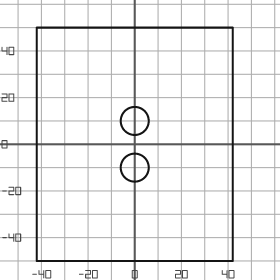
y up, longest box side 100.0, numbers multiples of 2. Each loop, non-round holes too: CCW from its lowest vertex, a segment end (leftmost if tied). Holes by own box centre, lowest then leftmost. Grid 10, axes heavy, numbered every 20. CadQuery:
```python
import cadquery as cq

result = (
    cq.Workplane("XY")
    .moveTo(-42.0, -50.0)
    .lineTo(42.0, -50.0)
    .lineTo(42.0, 50.0)
    .lineTo(-42.0, 50.0)
    .close()
    .moveTo(0.0, -10.0)
    .circle(6.0)
    .moveTo(0.0, 10.0)
    .circle(6.0)
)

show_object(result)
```